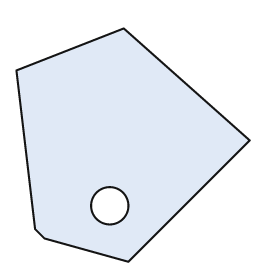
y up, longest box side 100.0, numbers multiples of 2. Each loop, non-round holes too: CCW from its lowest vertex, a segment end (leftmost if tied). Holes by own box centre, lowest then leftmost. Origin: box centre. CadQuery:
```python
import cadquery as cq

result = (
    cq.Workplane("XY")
    .moveTo(-2.0, -50.0)
    .lineTo(50.0, 2.0)
    .lineTo(-4.0, 50.0)
    .lineTo(-50.0, 32.0)
    .lineTo(-42.0, -36.0)
    .lineTo(-38.0, -40.0)
    .close()
    .moveTo(-10.0, -26.0)
    .circle(8.0)
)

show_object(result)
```